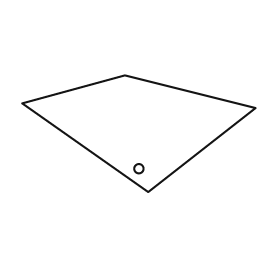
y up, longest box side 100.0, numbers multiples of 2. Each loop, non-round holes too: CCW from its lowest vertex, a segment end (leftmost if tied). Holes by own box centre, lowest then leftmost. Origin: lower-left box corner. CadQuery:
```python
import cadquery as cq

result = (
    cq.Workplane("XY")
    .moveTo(54.0, 0.0)
    .lineTo(100.0, 36.0)
    .lineTo(44.0, 50.0)
    .lineTo(0.0, 38.0)
    .close()
    .moveTo(50.0, 10.0)
    .circle(2.0)
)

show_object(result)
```